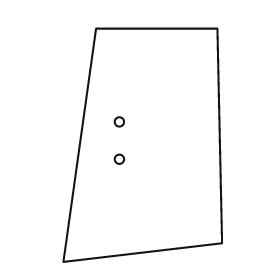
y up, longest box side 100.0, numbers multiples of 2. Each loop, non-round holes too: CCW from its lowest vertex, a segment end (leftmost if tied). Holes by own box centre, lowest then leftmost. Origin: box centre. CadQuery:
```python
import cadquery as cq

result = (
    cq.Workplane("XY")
    .moveTo(-34.0, -50.0)
    .lineTo(34.0, -42.0)
    .lineTo(32.0, 50.0)
    .lineTo(-20.0, 50.0)
    .close()
    .moveTo(-10.0, -6.0)
    .circle(2.0)
    .moveTo(-10.0, 10.0)
    .circle(2.0)
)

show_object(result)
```